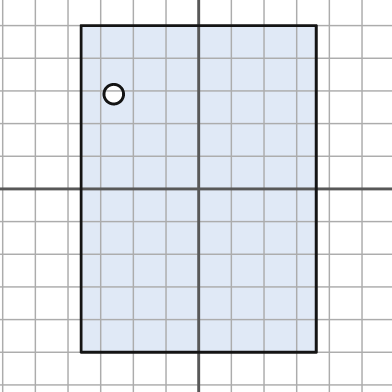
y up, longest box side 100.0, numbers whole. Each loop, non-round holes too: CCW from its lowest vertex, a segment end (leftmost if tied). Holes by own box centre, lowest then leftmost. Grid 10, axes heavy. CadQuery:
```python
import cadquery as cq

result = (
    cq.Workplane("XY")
    .moveTo(-36.0, -50.0)
    .lineTo(36.0, -50.0)
    .lineTo(36.0, 50.0)
    .lineTo(-36.0, 50.0)
    .close()
    .moveTo(-26.0, 29.0)
    .circle(3.0)
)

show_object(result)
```